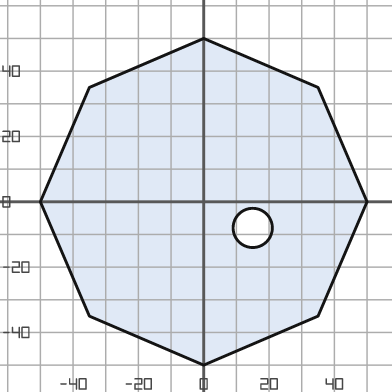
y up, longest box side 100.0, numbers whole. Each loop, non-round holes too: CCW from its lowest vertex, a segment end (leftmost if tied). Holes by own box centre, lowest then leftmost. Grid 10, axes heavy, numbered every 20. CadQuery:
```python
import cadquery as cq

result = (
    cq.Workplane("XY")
    .moveTo(0.0, -50.0)
    .lineTo(35.0, -35.0)
    .lineTo(50.0, 0.0)
    .lineTo(35.0, 35.0)
    .lineTo(0.0, 50.0)
    .lineTo(-35.0, 35.0)
    .lineTo(-50.0, 0.0)
    .lineTo(-35.0, -35.0)
    .close()
    .moveTo(15.0, -8.0)
    .circle(6.0)
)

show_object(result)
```